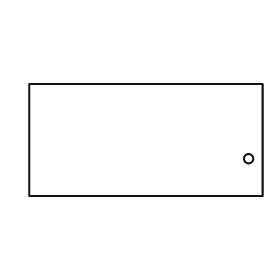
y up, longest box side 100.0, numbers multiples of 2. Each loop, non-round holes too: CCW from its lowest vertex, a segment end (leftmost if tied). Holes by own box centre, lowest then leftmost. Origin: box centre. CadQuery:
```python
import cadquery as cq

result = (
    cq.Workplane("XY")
    .moveTo(-50.0, -24.0)
    .lineTo(50.0, -24.0)
    .lineTo(50.0, 24.0)
    .lineTo(-50.0, 24.0)
    .close()
    .moveTo(44.0, -8.0)
    .circle(2.0)
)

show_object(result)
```